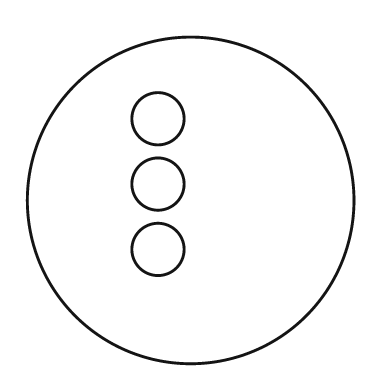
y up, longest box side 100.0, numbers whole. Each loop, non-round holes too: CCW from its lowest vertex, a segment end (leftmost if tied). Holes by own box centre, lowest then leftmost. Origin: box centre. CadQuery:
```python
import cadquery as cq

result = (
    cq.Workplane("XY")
    .moveTo(0.0, 0.0)
    .circle(50.0)
    .moveTo(-10.0, -15.0)
    .circle(8.0)
    .moveTo(-10.0, 5.0)
    .circle(8.0)
    .moveTo(-10.0, 25.0)
    .circle(8.0)
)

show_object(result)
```